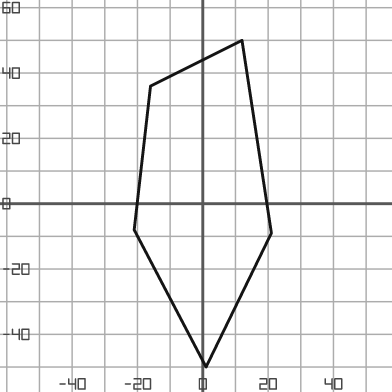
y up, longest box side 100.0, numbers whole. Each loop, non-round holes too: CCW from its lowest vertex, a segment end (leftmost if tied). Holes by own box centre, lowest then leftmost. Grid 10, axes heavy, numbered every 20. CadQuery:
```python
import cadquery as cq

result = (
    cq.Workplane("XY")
    .moveTo(1.0, -50.0)
    .lineTo(21.0, -9.0)
    .lineTo(12.0, 50.0)
    .lineTo(-16.0, 36.0)
    .lineTo(-21.0, -8.0)
    .close()
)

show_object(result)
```